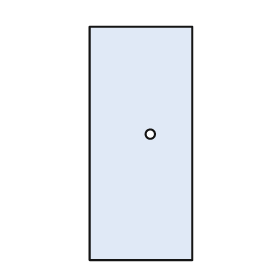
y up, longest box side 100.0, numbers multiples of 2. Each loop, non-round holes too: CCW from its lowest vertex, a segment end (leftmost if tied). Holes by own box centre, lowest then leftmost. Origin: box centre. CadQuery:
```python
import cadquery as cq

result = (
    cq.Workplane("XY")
    .moveTo(-22.0, -50.0)
    .lineTo(22.0, -50.0)
    .lineTo(22.0, 50.0)
    .lineTo(-22.0, 50.0)
    .close()
    .moveTo(4.0, 4.0)
    .circle(2.0)
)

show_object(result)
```